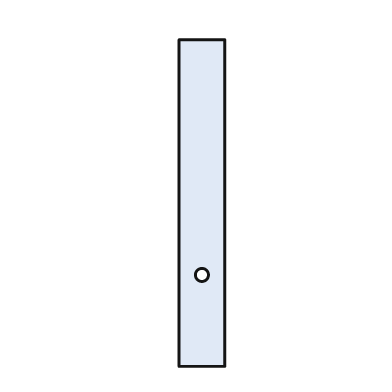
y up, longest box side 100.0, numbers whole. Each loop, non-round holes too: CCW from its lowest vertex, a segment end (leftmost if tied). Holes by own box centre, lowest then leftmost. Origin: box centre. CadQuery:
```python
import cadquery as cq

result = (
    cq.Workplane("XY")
    .moveTo(-7.0, -50.0)
    .lineTo(7.0, -50.0)
    .lineTo(7.0, 50.0)
    .lineTo(-7.0, 50.0)
    .close()
    .moveTo(0.0, -22.0)
    .circle(2.0)
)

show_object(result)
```